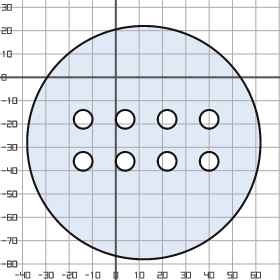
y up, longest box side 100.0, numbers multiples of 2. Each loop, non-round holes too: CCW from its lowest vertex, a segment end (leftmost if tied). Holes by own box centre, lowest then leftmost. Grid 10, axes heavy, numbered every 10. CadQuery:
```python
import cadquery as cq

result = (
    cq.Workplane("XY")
    .moveTo(12.0, -28.0)
    .circle(50.0)
    .moveTo(-14.0, -36.0)
    .circle(4.0)
    .moveTo(4.0, -36.0)
    .circle(4.0)
    .moveTo(22.0, -36.0)
    .circle(4.0)
    .moveTo(40.0, -36.0)
    .circle(4.0)
    .moveTo(-14.0, -18.0)
    .circle(4.0)
    .moveTo(4.0, -18.0)
    .circle(4.0)
    .moveTo(22.0, -18.0)
    .circle(4.0)
    .moveTo(40.0, -18.0)
    .circle(4.0)
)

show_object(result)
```